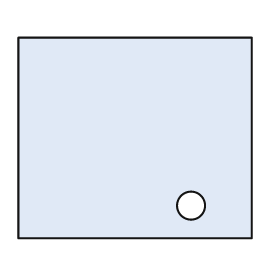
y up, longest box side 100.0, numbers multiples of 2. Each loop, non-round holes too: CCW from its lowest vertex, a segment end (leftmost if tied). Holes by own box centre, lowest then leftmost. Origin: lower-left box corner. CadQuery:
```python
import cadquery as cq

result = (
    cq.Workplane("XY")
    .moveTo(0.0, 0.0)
    .lineTo(100.0, 0.0)
    .lineTo(100.0, 86.0)
    .lineTo(0.0, 86.0)
    .close()
    .moveTo(74.0, 14.0)
    .circle(6.0)
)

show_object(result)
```